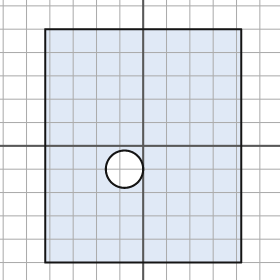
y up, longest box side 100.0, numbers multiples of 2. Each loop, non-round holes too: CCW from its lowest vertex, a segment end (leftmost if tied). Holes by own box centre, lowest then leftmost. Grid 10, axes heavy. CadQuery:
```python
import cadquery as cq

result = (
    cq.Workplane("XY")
    .moveTo(-42.0, -50.0)
    .lineTo(42.0, -50.0)
    .lineTo(42.0, 50.0)
    .lineTo(-42.0, 50.0)
    .close()
    .moveTo(-8.0, -10.0)
    .circle(8.0)
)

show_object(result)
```